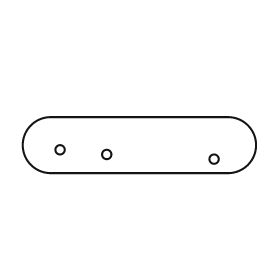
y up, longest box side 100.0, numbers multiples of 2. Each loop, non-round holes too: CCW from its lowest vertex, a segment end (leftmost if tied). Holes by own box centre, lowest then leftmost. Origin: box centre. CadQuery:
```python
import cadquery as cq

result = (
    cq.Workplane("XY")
    .moveTo(-38.0, -12.0)
    .lineTo(38.0, -12.0)
    .threePointArc((50.0, 0.0), (38.0, 12.0))
    .lineTo(-38.0, 12.0)
    .threePointArc((-50.0, 0.0), (-38.0, -12.0))
    .close()
    .moveTo(32.0, -6.0)
    .circle(2.0)
    .moveTo(-14.0, -4.0)
    .circle(2.0)
    .moveTo(-34.0, -2.0)
    .circle(2.0)
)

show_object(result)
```